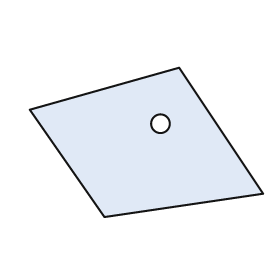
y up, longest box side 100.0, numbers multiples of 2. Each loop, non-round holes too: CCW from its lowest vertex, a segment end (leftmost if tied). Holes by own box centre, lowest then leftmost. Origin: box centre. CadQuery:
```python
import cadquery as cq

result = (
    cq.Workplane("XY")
    .moveTo(-18.0, -32.0)
    .lineTo(50.0, -22.0)
    .lineTo(14.0, 32.0)
    .lineTo(-50.0, 14.0)
    .close()
    .moveTo(6.0, 8.0)
    .circle(4.0)
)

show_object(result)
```